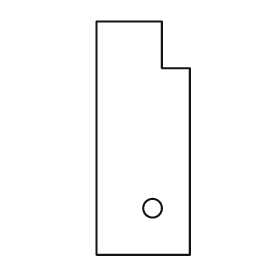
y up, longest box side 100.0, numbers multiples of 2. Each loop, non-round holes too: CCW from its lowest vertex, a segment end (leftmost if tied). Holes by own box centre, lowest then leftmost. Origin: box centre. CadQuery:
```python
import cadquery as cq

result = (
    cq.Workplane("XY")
    .moveTo(-20.0, -50.0)
    .lineTo(20.0, -50.0)
    .lineTo(20.0, 30.0)
    .lineTo(8.0, 30.0)
    .lineTo(8.0, 50.0)
    .lineTo(-20.0, 50.0)
    .close()
    .moveTo(4.0, -30.0)
    .circle(4.0)
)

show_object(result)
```